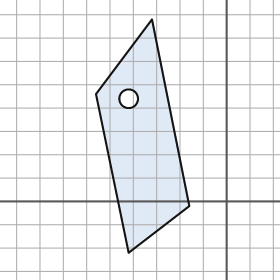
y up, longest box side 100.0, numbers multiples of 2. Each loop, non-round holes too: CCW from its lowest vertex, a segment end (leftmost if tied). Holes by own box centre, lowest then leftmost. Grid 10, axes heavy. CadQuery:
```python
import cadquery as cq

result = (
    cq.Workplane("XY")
    .moveTo(-42.0, -22.0)
    .lineTo(-16.0, -2.0)
    .lineTo(-32.0, 78.0)
    .lineTo(-56.0, 46.0)
    .close()
    .moveTo(-42.0, 44.0)
    .circle(4.0)
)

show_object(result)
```